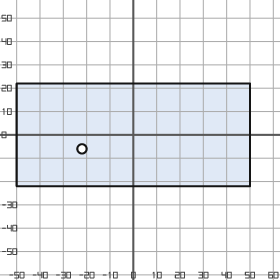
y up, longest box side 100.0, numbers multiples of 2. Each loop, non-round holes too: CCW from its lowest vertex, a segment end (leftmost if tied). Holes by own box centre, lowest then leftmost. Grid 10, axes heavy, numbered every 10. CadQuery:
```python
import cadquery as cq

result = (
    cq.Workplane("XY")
    .moveTo(-50.0, -22.0)
    .lineTo(50.0, -22.0)
    .lineTo(50.0, 22.0)
    .lineTo(-50.0, 22.0)
    .close()
    .moveTo(-22.0, -6.0)
    .circle(2.0)
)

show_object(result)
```